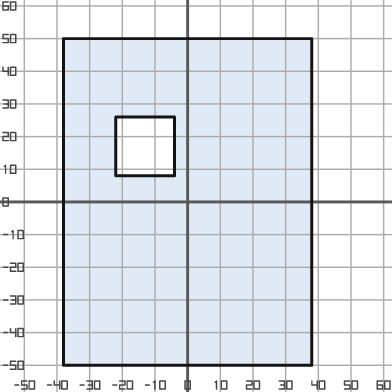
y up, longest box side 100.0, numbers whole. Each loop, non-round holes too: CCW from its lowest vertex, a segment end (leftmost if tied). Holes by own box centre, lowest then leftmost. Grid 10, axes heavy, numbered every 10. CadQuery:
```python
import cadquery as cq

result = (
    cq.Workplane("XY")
    .moveTo(-38.0, -50.0)
    .lineTo(38.0, -50.0)
    .lineTo(38.0, 50.0)
    .lineTo(-38.0, 50.0)
    .close()
    .moveTo(-22.0, 8.0)
    .lineTo(-4.0, 8.0)
    .lineTo(-4.0, 26.0)
    .lineTo(-22.0, 26.0)
    .close()
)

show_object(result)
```